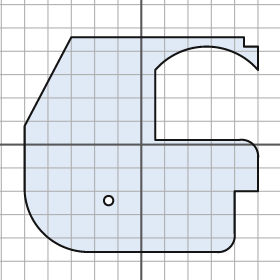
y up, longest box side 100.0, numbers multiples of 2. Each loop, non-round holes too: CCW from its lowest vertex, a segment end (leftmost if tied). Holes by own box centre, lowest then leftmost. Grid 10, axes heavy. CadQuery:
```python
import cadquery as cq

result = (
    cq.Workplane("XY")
    .moveTo(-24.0, -46.0)
    .lineTo(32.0, -46.0)
    .threePointArc((38.0, -44.0), (40.0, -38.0))
    .lineTo(40.0, -20.0)
    .lineTo(50.0, -20.0)
    .lineTo(50.0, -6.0)
    .threePointArc((48.0, 0.0), (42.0, 2.0))
    .lineTo(6.0, 2.0)
    .lineTo(6.0, 32.0)
    .threePointArc((28.0, 42.0), (50.0, 32.0))
    .lineTo(50.0, 42.0)
    .lineTo(44.0, 42.0)
    .lineTo(44.0, 46.0)
    .lineTo(-30.0, 46.0)
    .lineTo(-50.0, 8.0)
    .lineTo(-50.0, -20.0)
    .threePointArc((-42.0, -38.0), (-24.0, -46.0))
    .close()
    .moveTo(-14.0, -24.0)
    .circle(2.0)
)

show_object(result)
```